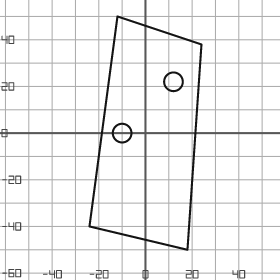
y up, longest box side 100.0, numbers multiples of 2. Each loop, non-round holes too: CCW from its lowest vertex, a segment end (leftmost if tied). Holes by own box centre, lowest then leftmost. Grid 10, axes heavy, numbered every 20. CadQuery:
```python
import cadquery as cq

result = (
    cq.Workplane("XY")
    .moveTo(18.0, -50.0)
    .lineTo(24.0, 38.0)
    .lineTo(-12.0, 50.0)
    .lineTo(-24.0, -40.0)
    .close()
    .moveTo(-10.0, 0.0)
    .circle(4.0)
    .moveTo(12.0, 22.0)
    .circle(4.0)
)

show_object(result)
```